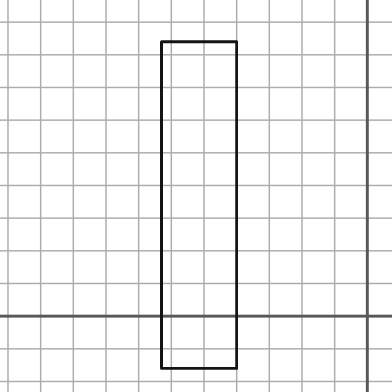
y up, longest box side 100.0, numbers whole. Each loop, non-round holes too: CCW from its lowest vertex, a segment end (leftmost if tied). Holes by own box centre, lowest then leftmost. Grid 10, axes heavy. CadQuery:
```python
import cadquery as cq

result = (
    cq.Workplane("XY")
    .moveTo(-63.0, -16.0)
    .lineTo(-40.0, -16.0)
    .lineTo(-40.0, 84.0)
    .lineTo(-63.0, 84.0)
    .close()
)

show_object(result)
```